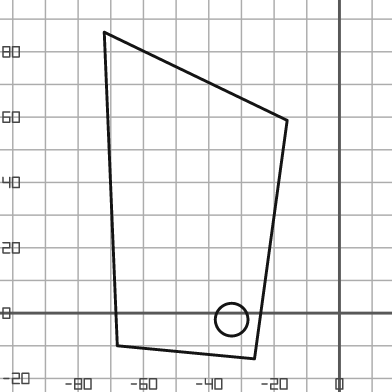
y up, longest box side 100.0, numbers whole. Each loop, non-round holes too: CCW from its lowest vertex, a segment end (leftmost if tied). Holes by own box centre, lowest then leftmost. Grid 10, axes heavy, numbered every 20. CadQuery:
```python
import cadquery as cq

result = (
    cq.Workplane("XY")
    .moveTo(-26.0, -14.0)
    .lineTo(-16.0, 59.0)
    .lineTo(-72.0, 86.0)
    .lineTo(-68.0, -10.0)
    .close()
    .moveTo(-33.0, -2.0)
    .circle(5.0)
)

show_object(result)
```